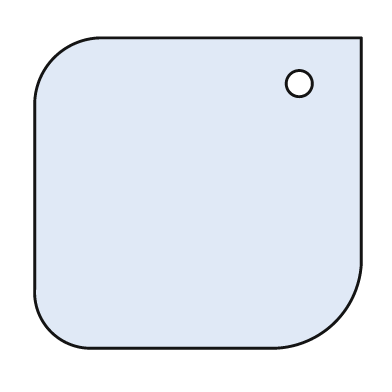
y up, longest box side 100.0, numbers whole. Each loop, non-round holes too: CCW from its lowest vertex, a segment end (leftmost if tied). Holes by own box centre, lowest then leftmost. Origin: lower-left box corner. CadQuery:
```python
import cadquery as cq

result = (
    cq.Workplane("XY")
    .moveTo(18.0, 0.0)
    .lineTo(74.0, 0.0)
    .threePointArc((92.0, 8.0), (100.0, 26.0))
    .lineTo(100.0, 95.0)
    .lineTo(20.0, 95.0)
    .threePointArc((6.0, 89.0), (0.0, 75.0))
    .lineTo(0.0, 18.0)
    .threePointArc((5.0, 5.0), (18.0, 0.0))
    .close()
    .moveTo(81.0, 81.0)
    .circle(4.0)
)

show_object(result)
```